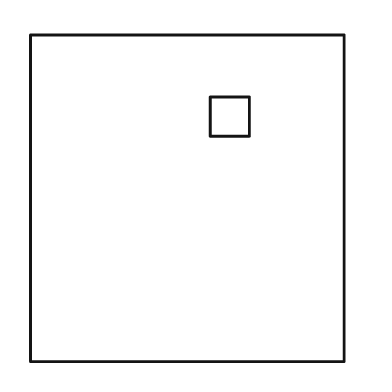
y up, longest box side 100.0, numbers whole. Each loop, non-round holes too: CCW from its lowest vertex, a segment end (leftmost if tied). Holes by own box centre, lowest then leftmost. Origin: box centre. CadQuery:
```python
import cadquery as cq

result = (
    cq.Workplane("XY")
    .moveTo(-48.0, -50.0)
    .lineTo(48.0, -50.0)
    .lineTo(48.0, 50.0)
    .lineTo(-48.0, 50.0)
    .close()
    .moveTo(7.0, 19.0)
    .lineTo(19.0, 19.0)
    .lineTo(19.0, 31.0)
    .lineTo(7.0, 31.0)
    .close()
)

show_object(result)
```